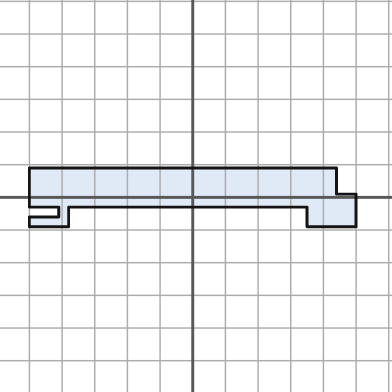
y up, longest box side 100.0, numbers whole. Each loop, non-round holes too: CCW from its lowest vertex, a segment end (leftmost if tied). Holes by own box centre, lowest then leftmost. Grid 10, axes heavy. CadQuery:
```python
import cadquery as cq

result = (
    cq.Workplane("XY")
    .moveTo(-50.0, -9.0)
    .lineTo(-38.0, -9.0)
    .lineTo(-38.0, -3.0)
    .lineTo(35.0, -3.0)
    .lineTo(35.0, -9.0)
    .lineTo(50.0, -9.0)
    .lineTo(50.0, 1.0)
    .lineTo(44.0, 1.0)
    .lineTo(44.0, 9.0)
    .lineTo(-50.0, 9.0)
    .lineTo(-50.0, -3.0)
    .lineTo(-41.0, -3.0)
    .lineTo(-41.0, -6.0)
    .lineTo(-50.0, -6.0)
    .close()
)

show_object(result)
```